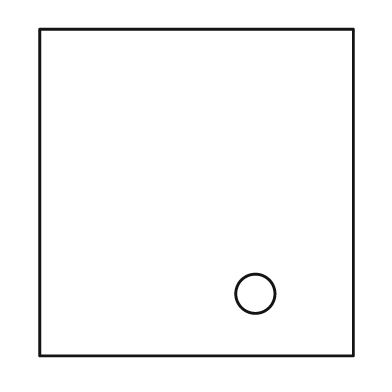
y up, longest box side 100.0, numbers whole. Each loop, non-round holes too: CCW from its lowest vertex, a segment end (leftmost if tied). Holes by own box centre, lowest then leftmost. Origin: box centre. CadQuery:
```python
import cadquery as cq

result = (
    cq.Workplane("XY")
    .moveTo(-48.0, -50.0)
    .lineTo(48.0, -50.0)
    .lineTo(48.0, 50.0)
    .lineTo(-48.0, 50.0)
    .close()
    .moveTo(18.0, -31.0)
    .circle(6.0)
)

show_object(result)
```